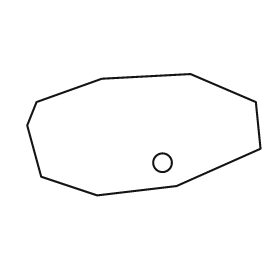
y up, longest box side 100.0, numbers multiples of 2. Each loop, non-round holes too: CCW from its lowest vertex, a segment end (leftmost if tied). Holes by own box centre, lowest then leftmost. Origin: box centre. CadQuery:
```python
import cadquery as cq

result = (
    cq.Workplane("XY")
    .moveTo(-20.0, -26.0)
    .lineTo(14.0, -22.0)
    .lineTo(50.0, -6.0)
    .lineTo(48.0, 14.0)
    .lineTo(20.0, 26.0)
    .lineTo(-18.0, 24.0)
    .lineTo(-46.0, 14.0)
    .lineTo(-50.0, 4.0)
    .lineTo(-44.0, -18.0)
    .close()
    .moveTo(8.0, -12.0)
    .circle(4.0)
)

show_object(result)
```